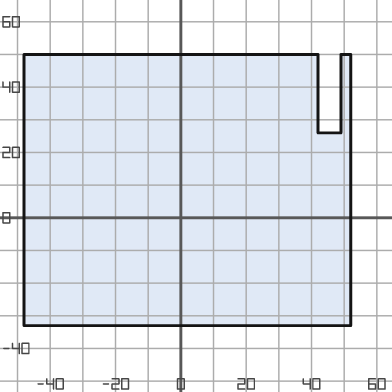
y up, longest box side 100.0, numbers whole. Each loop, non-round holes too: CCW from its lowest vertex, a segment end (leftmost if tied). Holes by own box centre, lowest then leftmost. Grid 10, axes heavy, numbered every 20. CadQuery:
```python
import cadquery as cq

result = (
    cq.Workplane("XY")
    .moveTo(-48.0, -33.0)
    .lineTo(52.0, -33.0)
    .lineTo(52.0, 50.0)
    .lineTo(49.0, 50.0)
    .lineTo(49.0, 26.0)
    .lineTo(42.0, 26.0)
    .lineTo(42.0, 50.0)
    .lineTo(-48.0, 50.0)
    .close()
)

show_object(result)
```